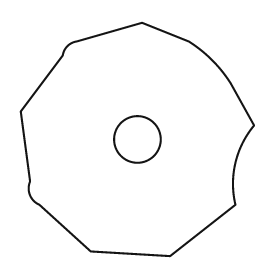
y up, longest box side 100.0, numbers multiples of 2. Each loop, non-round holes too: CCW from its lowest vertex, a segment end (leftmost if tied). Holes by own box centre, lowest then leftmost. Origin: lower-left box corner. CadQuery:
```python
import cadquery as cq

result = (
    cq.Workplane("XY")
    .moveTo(64.0, 0.0)
    .lineTo(92.0, 22.0)
    .threePointArc((92.0, 40.0), (100.0, 56.0))
    .lineTo(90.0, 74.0)
    .threePointArc((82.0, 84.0), (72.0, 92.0))
    .lineTo(52.0, 100.0)
    .lineTo(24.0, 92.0)
    .threePointArc((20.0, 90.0), (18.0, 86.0))
    .lineTo(0.0, 62.0)
    .lineTo(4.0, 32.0)
    .threePointArc((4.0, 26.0), (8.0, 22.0))
    .lineTo(30.0, 2.0)
    .close()
    .moveTo(50.0, 50.0)
    .circle(10.0)
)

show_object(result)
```